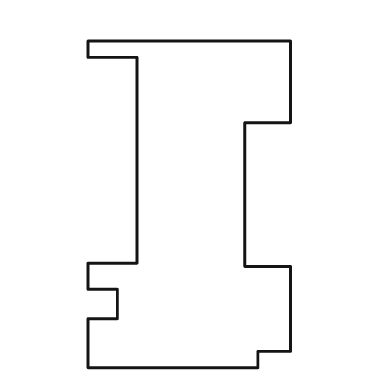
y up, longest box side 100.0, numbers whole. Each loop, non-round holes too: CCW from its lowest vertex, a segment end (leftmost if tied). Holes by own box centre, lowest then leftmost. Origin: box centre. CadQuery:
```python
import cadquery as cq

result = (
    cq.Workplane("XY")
    .moveTo(-31.0, -50.0)
    .lineTo(21.0, -50.0)
    .lineTo(21.0, -45.0)
    .lineTo(31.0, -45.0)
    .lineTo(31.0, -19.0)
    .lineTo(17.0, -19.0)
    .lineTo(17.0, 25.0)
    .lineTo(31.0, 25.0)
    .lineTo(31.0, 50.0)
    .lineTo(-31.0, 50.0)
    .lineTo(-31.0, 45.0)
    .lineTo(-16.0, 45.0)
    .lineTo(-16.0, -18.0)
    .lineTo(-31.0, -18.0)
    .lineTo(-31.0, -26.0)
    .lineTo(-22.0, -26.0)
    .lineTo(-22.0, -35.0)
    .lineTo(-31.0, -35.0)
    .close()
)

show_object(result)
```